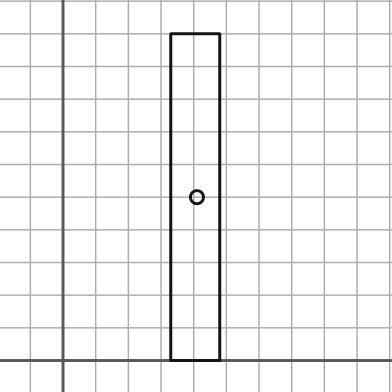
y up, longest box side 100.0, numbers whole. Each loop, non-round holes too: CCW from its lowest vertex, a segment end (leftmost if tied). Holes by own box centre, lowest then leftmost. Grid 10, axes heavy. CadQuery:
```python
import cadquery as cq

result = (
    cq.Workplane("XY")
    .moveTo(33.0, 0.0)
    .lineTo(48.0, 0.0)
    .lineTo(48.0, 100.0)
    .lineTo(33.0, 100.0)
    .close()
    .moveTo(41.0, 50.0)
    .circle(2.0)
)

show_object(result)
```